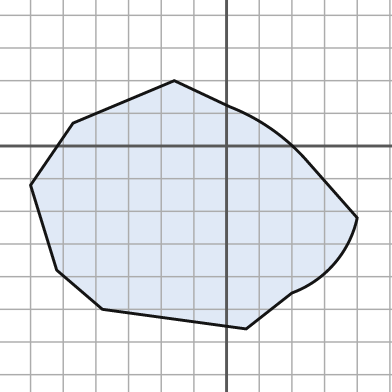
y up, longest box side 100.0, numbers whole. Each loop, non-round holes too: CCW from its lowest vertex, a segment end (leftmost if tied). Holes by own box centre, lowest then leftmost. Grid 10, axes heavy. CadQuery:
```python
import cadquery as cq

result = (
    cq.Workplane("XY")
    .moveTo(6.0, -56.0)
    .lineTo(20.0, -45.0)
    .threePointArc((33.0, -36.0), (40.0, -22.0))
    .lineTo(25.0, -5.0)
    .threePointArc((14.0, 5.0), (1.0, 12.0))
    .lineTo(-16.0, 20.0)
    .lineTo(-47.0, 7.0)
    .lineTo(-60.0, -12.0)
    .lineTo(-52.0, -38.0)
    .lineTo(-38.0, -50.0)
    .close()
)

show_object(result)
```